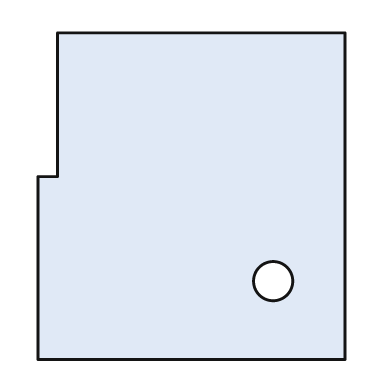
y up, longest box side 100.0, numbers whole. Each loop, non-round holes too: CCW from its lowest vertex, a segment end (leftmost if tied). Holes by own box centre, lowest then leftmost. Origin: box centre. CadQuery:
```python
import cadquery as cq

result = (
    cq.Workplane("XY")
    .moveTo(-47.0, -50.0)
    .lineTo(47.0, -50.0)
    .lineTo(47.0, 50.0)
    .lineTo(-41.0, 50.0)
    .lineTo(-41.0, 6.0)
    .lineTo(-47.0, 6.0)
    .close()
    .moveTo(25.0, -26.0)
    .circle(6.0)
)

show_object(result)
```